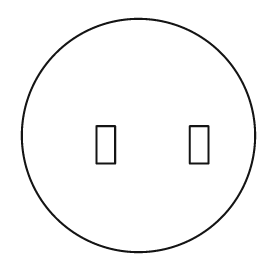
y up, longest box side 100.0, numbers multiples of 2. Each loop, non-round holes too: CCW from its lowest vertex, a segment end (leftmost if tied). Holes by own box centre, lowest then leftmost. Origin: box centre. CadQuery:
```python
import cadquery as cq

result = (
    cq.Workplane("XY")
    .moveTo(0.0, 0.0)
    .circle(50.0)
    .moveTo(-18.0, -12.0)
    .lineTo(-10.0, -12.0)
    .lineTo(-10.0, 4.0)
    .lineTo(-18.0, 4.0)
    .close()
    .moveTo(22.0, -12.0)
    .lineTo(30.0, -12.0)
    .lineTo(30.0, 4.0)
    .lineTo(22.0, 4.0)
    .close()
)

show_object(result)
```